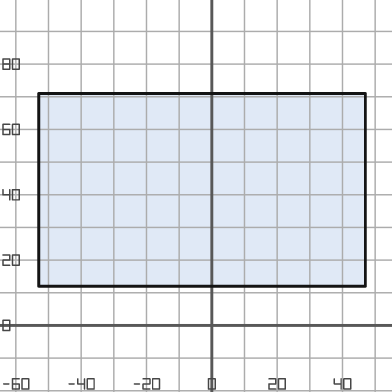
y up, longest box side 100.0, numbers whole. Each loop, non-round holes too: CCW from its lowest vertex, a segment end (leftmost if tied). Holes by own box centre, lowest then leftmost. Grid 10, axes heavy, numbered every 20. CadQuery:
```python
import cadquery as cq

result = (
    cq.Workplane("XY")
    .moveTo(-53.0, 12.0)
    .lineTo(47.0, 12.0)
    .lineTo(47.0, 71.0)
    .lineTo(-53.0, 71.0)
    .close()
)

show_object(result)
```